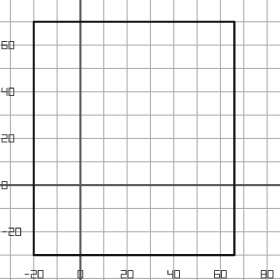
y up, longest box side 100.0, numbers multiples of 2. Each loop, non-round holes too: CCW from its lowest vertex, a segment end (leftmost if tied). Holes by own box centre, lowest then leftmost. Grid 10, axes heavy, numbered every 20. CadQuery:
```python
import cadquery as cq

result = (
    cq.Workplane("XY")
    .moveTo(-20.0, -30.0)
    .lineTo(66.0, -30.0)
    .lineTo(66.0, 70.0)
    .lineTo(-20.0, 70.0)
    .close()
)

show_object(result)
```